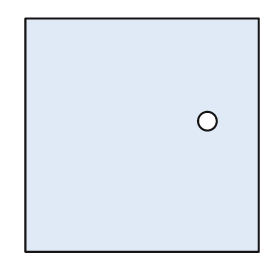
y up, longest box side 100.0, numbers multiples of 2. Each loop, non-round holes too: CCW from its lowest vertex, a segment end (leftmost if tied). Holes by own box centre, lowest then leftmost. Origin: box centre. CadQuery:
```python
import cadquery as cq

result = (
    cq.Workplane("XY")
    .moveTo(-50.0, -50.0)
    .lineTo(50.0, -50.0)
    .lineTo(50.0, 50.0)
    .lineTo(-50.0, 50.0)
    .close()
    .moveTo(28.0, 6.0)
    .circle(4.0)
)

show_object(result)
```